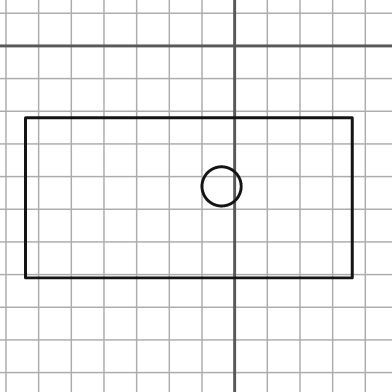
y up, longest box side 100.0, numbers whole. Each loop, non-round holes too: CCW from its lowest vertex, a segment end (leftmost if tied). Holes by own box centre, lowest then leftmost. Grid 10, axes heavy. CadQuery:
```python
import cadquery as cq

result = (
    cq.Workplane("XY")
    .moveTo(-64.0, -71.0)
    .lineTo(36.0, -71.0)
    .lineTo(36.0, -22.0)
    .lineTo(-64.0, -22.0)
    .close()
    .moveTo(-4.0, -43.0)
    .circle(6.0)
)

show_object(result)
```